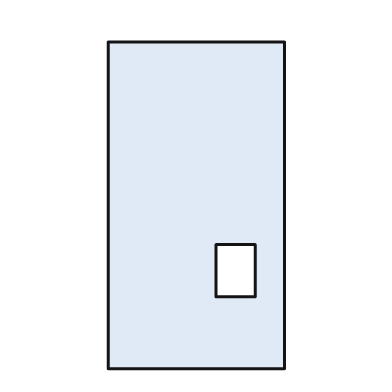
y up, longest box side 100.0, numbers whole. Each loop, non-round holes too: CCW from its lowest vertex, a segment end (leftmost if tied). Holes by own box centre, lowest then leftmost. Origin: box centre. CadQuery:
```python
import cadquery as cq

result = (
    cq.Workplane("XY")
    .moveTo(-27.0, -50.0)
    .lineTo(27.0, -50.0)
    .lineTo(27.0, 50.0)
    .lineTo(-27.0, 50.0)
    .close()
    .moveTo(6.0, -28.0)
    .lineTo(18.0, -28.0)
    .lineTo(18.0, -12.0)
    .lineTo(6.0, -12.0)
    .close()
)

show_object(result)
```